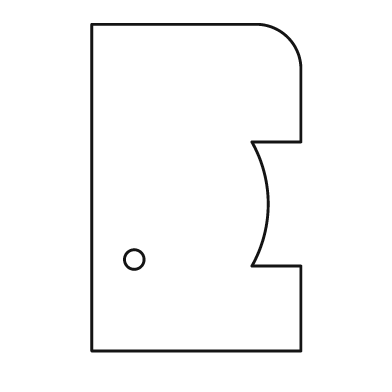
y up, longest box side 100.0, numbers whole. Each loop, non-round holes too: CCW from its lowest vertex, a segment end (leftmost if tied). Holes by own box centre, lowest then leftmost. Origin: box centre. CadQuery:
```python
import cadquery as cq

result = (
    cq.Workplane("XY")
    .moveTo(-32.0, -50.0)
    .lineTo(32.0, -50.0)
    .lineTo(32.0, -24.0)
    .lineTo(17.0, -24.0)
    .threePointArc((22.0, -5.0), (17.0, 14.0))
    .lineTo(32.0, 14.0)
    .lineTo(32.0, 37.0)
    .threePointArc((28.0, 46.0), (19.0, 50.0))
    .lineTo(-32.0, 50.0)
    .close()
    .moveTo(-19.0, -22.0)
    .circle(3.0)
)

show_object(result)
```